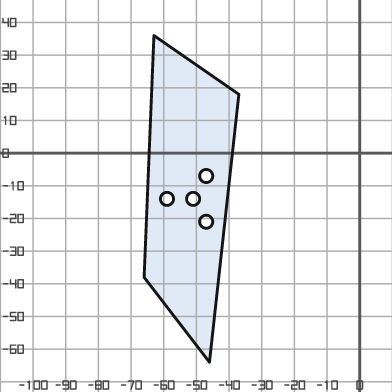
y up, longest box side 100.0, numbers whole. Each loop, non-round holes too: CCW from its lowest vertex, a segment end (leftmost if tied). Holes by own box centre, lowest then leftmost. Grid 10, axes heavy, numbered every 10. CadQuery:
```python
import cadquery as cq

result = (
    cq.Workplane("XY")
    .moveTo(-46.0, -64.0)
    .lineTo(-37.0, 18.0)
    .lineTo(-63.0, 36.0)
    .lineTo(-66.0, -38.0)
    .close()
    .moveTo(-47.0, -21.0)
    .circle(2.0)
    .moveTo(-59.0, -14.0)
    .circle(2.0)
    .moveTo(-51.0, -14.0)
    .circle(2.0)
    .moveTo(-47.0, -7.0)
    .circle(2.0)
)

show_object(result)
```